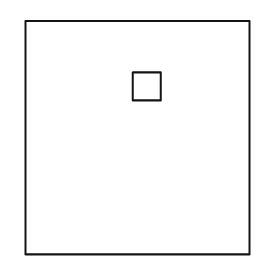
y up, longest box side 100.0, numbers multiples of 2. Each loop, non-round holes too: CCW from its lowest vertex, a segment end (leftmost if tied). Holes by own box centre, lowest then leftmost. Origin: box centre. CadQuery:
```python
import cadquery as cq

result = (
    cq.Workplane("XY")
    .moveTo(-48.0, -50.0)
    .lineTo(48.0, -50.0)
    .lineTo(48.0, 50.0)
    .lineTo(-48.0, 50.0)
    .close()
    .moveTo(-2.0, 16.0)
    .lineTo(10.0, 16.0)
    .lineTo(10.0, 28.0)
    .lineTo(-2.0, 28.0)
    .close()
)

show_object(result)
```